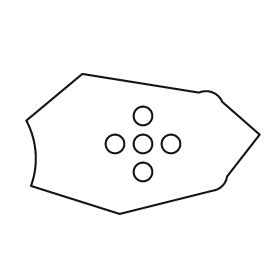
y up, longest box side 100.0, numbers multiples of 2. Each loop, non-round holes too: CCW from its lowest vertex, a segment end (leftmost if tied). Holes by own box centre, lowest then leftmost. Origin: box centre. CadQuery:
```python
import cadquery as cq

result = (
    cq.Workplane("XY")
    .moveTo(-10.0, -30.0)
    .lineTo(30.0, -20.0)
    .threePointArc((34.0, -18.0), (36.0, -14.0))
    .lineTo(50.0, 4.0)
    .lineTo(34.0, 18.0)
    .threePointArc((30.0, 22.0), (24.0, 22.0))
    .lineTo(-26.0, 30.0)
    .lineTo(-50.0, 10.0)
    .threePointArc((-46.0, -4.0), (-48.0, -18.0))
    .close()
    .moveTo(0.0, -12.0)
    .circle(4.0)
    .moveTo(-12.0, 0.0)
    .circle(4.0)
    .moveTo(0.0, 0.0)
    .circle(4.0)
    .moveTo(12.0, 0.0)
    .circle(4.0)
    .moveTo(0.0, 12.0)
    .circle(4.0)
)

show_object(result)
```